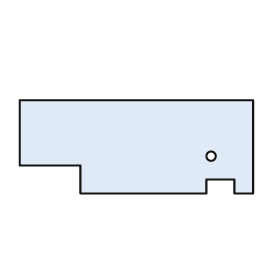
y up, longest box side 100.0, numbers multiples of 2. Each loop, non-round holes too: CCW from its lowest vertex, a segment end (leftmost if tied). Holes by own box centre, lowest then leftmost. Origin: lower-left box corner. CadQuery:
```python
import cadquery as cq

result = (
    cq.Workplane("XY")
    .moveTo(26.0, 0.0)
    .lineTo(80.0, 0.0)
    .lineTo(80.0, 6.0)
    .lineTo(92.0, 6.0)
    .lineTo(92.0, 0.0)
    .lineTo(100.0, 0.0)
    .lineTo(100.0, 40.0)
    .lineTo(0.0, 40.0)
    .lineTo(0.0, 12.0)
    .lineTo(26.0, 12.0)
    .close()
    .moveTo(82.0, 16.0)
    .circle(2.0)
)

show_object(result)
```